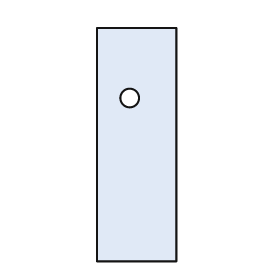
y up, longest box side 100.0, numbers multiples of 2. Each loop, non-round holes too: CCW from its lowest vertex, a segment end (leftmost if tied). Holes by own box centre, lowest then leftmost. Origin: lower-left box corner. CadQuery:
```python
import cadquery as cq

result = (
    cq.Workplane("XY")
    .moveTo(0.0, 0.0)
    .lineTo(34.0, 0.0)
    .lineTo(34.0, 100.0)
    .lineTo(0.0, 100.0)
    .close()
    .moveTo(14.0, 70.0)
    .circle(4.0)
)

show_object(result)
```